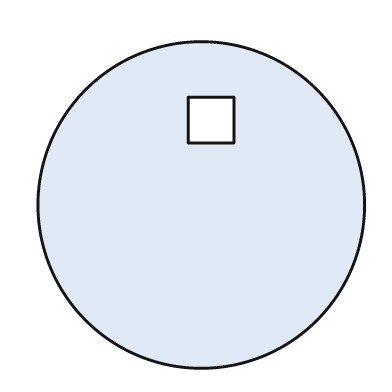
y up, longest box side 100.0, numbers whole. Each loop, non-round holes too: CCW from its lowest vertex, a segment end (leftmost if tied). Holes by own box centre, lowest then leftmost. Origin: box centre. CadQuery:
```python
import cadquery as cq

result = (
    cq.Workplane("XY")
    .moveTo(0.0, 0.0)
    .circle(50.0)
    .moveTo(-4.0, 19.0)
    .lineTo(10.0, 19.0)
    .lineTo(10.0, 33.0)
    .lineTo(-4.0, 33.0)
    .close()
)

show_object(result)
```